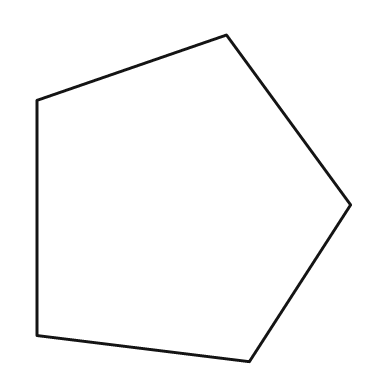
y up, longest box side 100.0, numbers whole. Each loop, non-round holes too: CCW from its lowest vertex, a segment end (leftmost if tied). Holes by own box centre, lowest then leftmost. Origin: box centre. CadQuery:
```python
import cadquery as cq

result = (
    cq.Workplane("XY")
    .moveTo(17.0, -50.0)
    .lineTo(48.0, -2.0)
    .lineTo(10.0, 50.0)
    .lineTo(-48.0, 30.0)
    .lineTo(-48.0, -42.0)
    .close()
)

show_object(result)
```